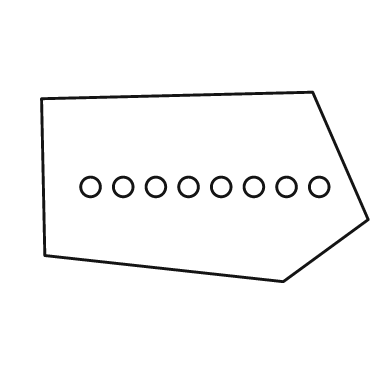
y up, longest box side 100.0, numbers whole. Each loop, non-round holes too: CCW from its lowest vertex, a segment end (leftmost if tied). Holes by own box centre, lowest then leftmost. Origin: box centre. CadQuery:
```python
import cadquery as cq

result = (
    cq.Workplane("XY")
    .moveTo(24.0, -29.0)
    .lineTo(50.0, -10.0)
    .lineTo(33.0, 29.0)
    .lineTo(-50.0, 27.0)
    .lineTo(-49.0, -21.0)
    .close()
    .moveTo(-35.0, 0.0)
    .circle(3.0)
    .moveTo(-25.0, 0.0)
    .circle(3.0)
    .moveTo(-15.0, 0.0)
    .circle(3.0)
    .moveTo(-5.0, 0.0)
    .circle(3.0)
    .moveTo(5.0, 0.0)
    .circle(3.0)
    .moveTo(15.0, 0.0)
    .circle(3.0)
    .moveTo(25.0, 0.0)
    .circle(3.0)
    .moveTo(35.0, 0.0)
    .circle(3.0)
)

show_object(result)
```